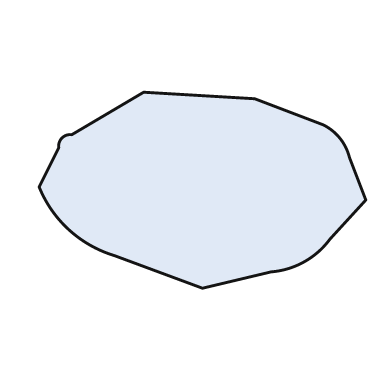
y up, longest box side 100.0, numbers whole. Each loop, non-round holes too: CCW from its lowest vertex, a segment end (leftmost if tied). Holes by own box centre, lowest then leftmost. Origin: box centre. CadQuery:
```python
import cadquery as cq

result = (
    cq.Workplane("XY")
    .moveTo(0.0, -30.0)
    .lineTo(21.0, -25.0)
    .threePointArc((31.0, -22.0), (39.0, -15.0))
    .lineTo(50.0, -3.0)
    .lineTo(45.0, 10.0)
    .threePointArc((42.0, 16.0), (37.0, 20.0))
    .lineTo(16.0, 28.0)
    .lineTo(-18.0, 30.0)
    .lineTo(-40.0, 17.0)
    .threePointArc((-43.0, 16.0), (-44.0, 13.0))
    .lineTo(-50.0, 1.0)
    .threePointArc((-41.0, -12.0), (-27.0, -20.0))
    .close()
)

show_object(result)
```